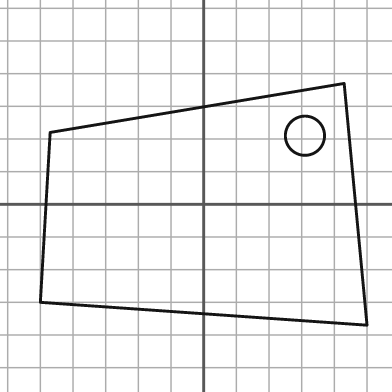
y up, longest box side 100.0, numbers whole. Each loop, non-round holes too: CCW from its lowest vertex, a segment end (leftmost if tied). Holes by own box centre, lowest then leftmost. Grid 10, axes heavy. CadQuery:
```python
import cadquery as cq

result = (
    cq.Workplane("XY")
    .moveTo(50.0, -37.0)
    .lineTo(43.0, 37.0)
    .lineTo(-47.0, 22.0)
    .lineTo(-50.0, -30.0)
    .close()
    .moveTo(31.0, 21.0)
    .circle(6.0)
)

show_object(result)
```